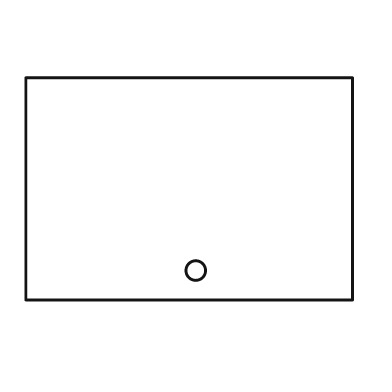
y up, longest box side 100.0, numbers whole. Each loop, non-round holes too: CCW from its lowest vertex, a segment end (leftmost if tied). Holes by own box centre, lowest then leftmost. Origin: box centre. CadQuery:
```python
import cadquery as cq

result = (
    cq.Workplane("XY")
    .moveTo(-50.0, -34.0)
    .lineTo(50.0, -34.0)
    .lineTo(50.0, 34.0)
    .lineTo(-50.0, 34.0)
    .close()
    .moveTo(2.0, -25.0)
    .circle(3.0)
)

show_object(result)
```